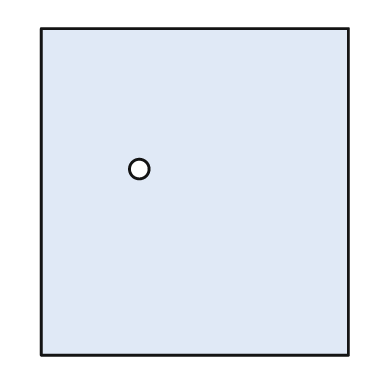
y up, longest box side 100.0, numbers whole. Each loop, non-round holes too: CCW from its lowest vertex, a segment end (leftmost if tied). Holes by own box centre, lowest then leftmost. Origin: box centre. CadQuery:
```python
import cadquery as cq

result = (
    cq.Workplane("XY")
    .moveTo(-47.0, -50.0)
    .lineTo(47.0, -50.0)
    .lineTo(47.0, 50.0)
    .lineTo(-47.0, 50.0)
    .close()
    .moveTo(-17.0, 7.0)
    .circle(3.0)
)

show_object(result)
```